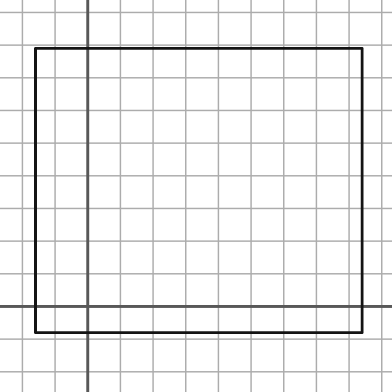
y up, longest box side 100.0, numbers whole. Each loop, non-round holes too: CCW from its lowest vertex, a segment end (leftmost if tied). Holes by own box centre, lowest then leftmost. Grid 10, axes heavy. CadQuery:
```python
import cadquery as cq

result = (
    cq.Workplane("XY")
    .moveTo(-16.0, -8.0)
    .lineTo(84.0, -8.0)
    .lineTo(84.0, 79.0)
    .lineTo(-16.0, 79.0)
    .close()
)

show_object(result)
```